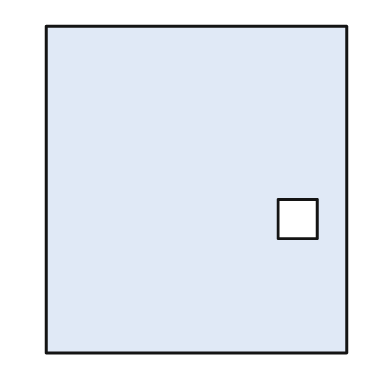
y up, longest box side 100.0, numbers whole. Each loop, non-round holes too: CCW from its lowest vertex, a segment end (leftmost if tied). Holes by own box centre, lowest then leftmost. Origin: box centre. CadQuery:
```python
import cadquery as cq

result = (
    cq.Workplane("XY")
    .moveTo(-46.0, -50.0)
    .lineTo(46.0, -50.0)
    .lineTo(46.0, 50.0)
    .lineTo(-46.0, 50.0)
    .close()
    .moveTo(25.0, -15.0)
    .lineTo(37.0, -15.0)
    .lineTo(37.0, -3.0)
    .lineTo(25.0, -3.0)
    .close()
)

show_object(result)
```